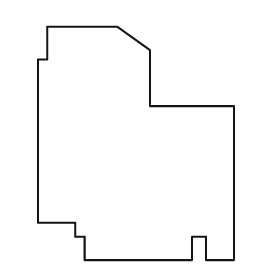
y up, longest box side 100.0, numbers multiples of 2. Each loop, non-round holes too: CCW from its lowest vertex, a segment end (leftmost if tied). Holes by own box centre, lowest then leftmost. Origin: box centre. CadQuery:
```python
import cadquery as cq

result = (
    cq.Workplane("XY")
    .moveTo(-22.0, -50.0)
    .lineTo(24.0, -50.0)
    .lineTo(24.0, -40.0)
    .lineTo(30.0, -40.0)
    .lineTo(30.0, -50.0)
    .lineTo(42.0, -50.0)
    .lineTo(42.0, 16.0)
    .lineTo(6.0, 16.0)
    .lineTo(6.0, 40.0)
    .lineTo(-8.0, 50.0)
    .lineTo(-38.0, 50.0)
    .lineTo(-38.0, 36.0)
    .lineTo(-42.0, 36.0)
    .lineTo(-42.0, -34.0)
    .lineTo(-26.0, -34.0)
    .lineTo(-26.0, -40.0)
    .lineTo(-22.0, -40.0)
    .close()
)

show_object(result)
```